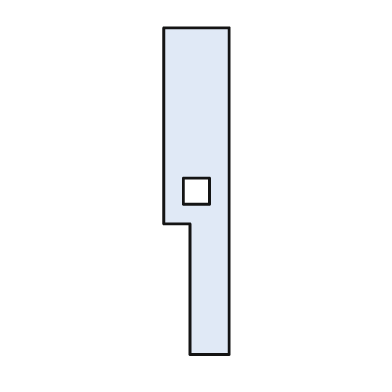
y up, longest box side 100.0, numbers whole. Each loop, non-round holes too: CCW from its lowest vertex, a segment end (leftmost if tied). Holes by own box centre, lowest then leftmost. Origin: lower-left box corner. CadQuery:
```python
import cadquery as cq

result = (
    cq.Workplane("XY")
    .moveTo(8.0, 0.0)
    .lineTo(20.0, 0.0)
    .lineTo(20.0, 100.0)
    .lineTo(0.0, 100.0)
    .lineTo(0.0, 40.0)
    .lineTo(8.0, 40.0)
    .close()
    .moveTo(6.0, 46.0)
    .lineTo(14.0, 46.0)
    .lineTo(14.0, 54.0)
    .lineTo(6.0, 54.0)
    .close()
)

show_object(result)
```